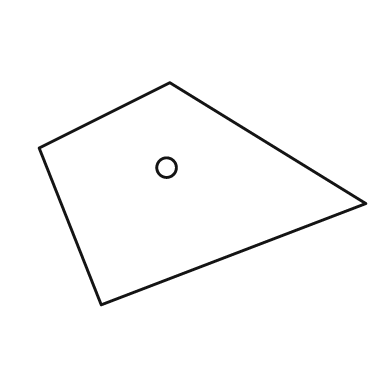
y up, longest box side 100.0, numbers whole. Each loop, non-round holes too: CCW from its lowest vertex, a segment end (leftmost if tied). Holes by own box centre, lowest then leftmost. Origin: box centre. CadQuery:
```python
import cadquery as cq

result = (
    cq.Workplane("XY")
    .moveTo(-31.0, -34.0)
    .lineTo(50.0, -3.0)
    .lineTo(-10.0, 34.0)
    .lineTo(-50.0, 14.0)
    .close()
    .moveTo(-11.0, 8.0)
    .circle(3.0)
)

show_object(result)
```